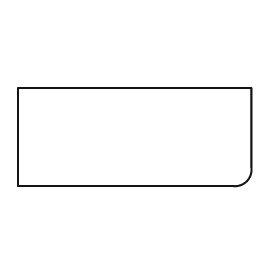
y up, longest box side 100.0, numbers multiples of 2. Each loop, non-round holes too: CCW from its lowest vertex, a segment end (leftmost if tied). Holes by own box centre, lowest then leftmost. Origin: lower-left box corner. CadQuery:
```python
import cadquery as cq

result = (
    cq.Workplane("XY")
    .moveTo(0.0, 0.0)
    .lineTo(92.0, 0.0)
    .threePointArc((98.0, 2.0), (100.0, 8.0))
    .lineTo(100.0, 42.0)
    .lineTo(0.0, 42.0)
    .close()
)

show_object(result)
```